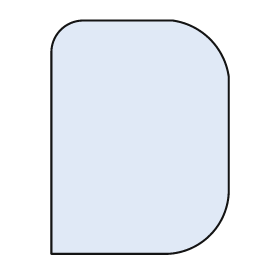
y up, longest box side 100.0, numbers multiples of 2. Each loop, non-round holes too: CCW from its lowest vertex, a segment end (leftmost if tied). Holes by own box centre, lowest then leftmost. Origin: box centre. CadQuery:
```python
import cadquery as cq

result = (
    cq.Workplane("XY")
    .moveTo(-38.0, -50.0)
    .lineTo(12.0, -50.0)
    .threePointArc((30.0, -42.0), (38.0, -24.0))
    .lineTo(38.0, 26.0)
    .threePointArc((30.0, 42.0), (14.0, 50.0))
    .lineTo(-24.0, 50.0)
    .threePointArc((-34.0, 46.0), (-38.0, 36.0))
    .close()
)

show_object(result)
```